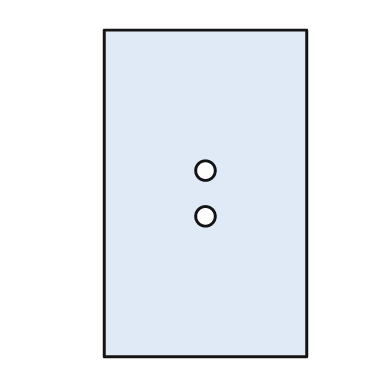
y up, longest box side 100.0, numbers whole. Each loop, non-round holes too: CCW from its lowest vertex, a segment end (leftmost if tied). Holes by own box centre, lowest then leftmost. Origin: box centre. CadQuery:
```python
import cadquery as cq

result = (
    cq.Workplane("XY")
    .moveTo(-31.0, -50.0)
    .lineTo(31.0, -50.0)
    .lineTo(31.0, 50.0)
    .lineTo(-31.0, 50.0)
    .close()
    .moveTo(0.0, -7.0)
    .circle(3.0)
    .moveTo(0.0, 7.0)
    .circle(3.0)
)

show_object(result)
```